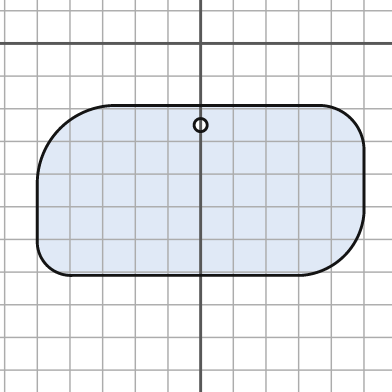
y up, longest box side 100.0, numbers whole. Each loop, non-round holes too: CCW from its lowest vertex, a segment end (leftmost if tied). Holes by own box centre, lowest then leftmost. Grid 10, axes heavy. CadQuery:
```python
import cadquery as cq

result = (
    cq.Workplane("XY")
    .moveTo(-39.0, -71.0)
    .lineTo(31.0, -71.0)
    .threePointArc((44.0, -65.0), (50.0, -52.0))
    .lineTo(50.0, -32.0)
    .threePointArc((46.0, -23.0), (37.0, -19.0))
    .lineTo(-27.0, -19.0)
    .threePointArc((-43.0, -26.0), (-50.0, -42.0))
    .lineTo(-50.0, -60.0)
    .threePointArc((-47.0, -68.0), (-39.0, -71.0))
    .close()
    .moveTo(0.0, -25.0)
    .circle(2.0)
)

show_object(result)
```